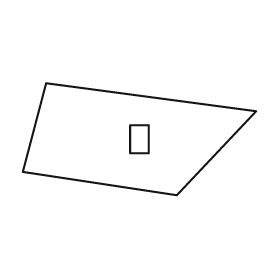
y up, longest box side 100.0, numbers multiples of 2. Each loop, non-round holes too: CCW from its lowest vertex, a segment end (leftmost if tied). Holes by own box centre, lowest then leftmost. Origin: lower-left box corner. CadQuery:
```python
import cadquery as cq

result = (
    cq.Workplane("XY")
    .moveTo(66.0, 0.0)
    .lineTo(100.0, 36.0)
    .lineTo(10.0, 48.0)
    .lineTo(0.0, 10.0)
    .close()
    .moveTo(46.0, 18.0)
    .lineTo(54.0, 18.0)
    .lineTo(54.0, 30.0)
    .lineTo(46.0, 30.0)
    .close()
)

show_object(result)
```